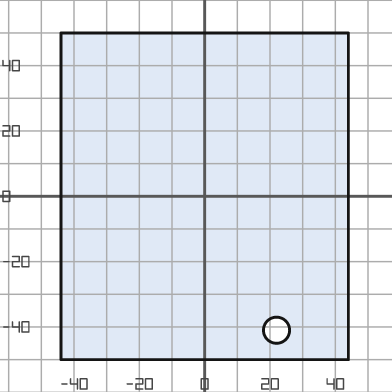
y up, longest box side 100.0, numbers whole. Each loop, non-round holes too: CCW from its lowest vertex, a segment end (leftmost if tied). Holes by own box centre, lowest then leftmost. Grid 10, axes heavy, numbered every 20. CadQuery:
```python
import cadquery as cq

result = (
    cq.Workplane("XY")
    .moveTo(-44.0, -50.0)
    .lineTo(44.0, -50.0)
    .lineTo(44.0, 50.0)
    .lineTo(-44.0, 50.0)
    .close()
    .moveTo(22.0, -41.0)
    .circle(4.0)
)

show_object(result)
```